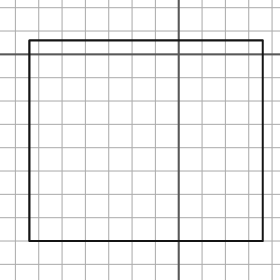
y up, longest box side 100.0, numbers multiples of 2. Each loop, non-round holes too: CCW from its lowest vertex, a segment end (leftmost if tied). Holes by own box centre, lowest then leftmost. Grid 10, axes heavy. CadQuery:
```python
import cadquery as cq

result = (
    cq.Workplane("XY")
    .moveTo(-64.0, -80.0)
    .lineTo(36.0, -80.0)
    .lineTo(36.0, 6.0)
    .lineTo(-64.0, 6.0)
    .close()
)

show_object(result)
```